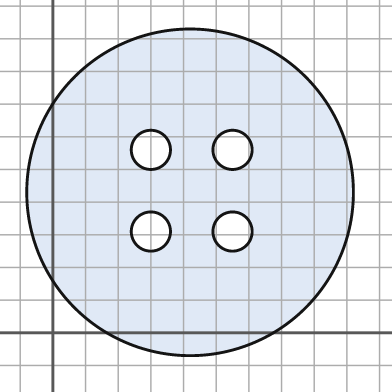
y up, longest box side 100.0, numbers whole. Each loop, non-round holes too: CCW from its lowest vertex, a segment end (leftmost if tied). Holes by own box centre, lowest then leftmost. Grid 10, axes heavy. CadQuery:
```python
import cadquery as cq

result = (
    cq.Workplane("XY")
    .moveTo(42.0, 43.0)
    .circle(50.0)
    .moveTo(30.0, 31.0)
    .circle(6.0)
    .moveTo(55.0, 31.0)
    .circle(6.0)
    .moveTo(30.0, 56.0)
    .circle(6.0)
    .moveTo(55.0, 56.0)
    .circle(6.0)
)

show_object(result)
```